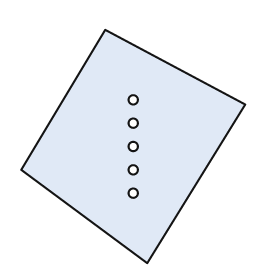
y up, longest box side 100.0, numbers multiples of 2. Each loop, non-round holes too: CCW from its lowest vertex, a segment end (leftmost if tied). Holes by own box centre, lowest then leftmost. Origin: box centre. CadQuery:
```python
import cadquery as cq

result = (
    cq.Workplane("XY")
    .moveTo(6.0, -50.0)
    .lineTo(48.0, 18.0)
    .lineTo(-12.0, 50.0)
    .lineTo(-48.0, -10.0)
    .close()
    .moveTo(0.0, -20.0)
    .circle(2.0)
    .moveTo(0.0, -10.0)
    .circle(2.0)
    .moveTo(0.0, 0.0)
    .circle(2.0)
    .moveTo(0.0, 10.0)
    .circle(2.0)
    .moveTo(0.0, 20.0)
    .circle(2.0)
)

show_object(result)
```